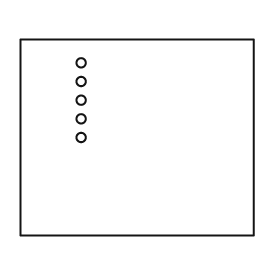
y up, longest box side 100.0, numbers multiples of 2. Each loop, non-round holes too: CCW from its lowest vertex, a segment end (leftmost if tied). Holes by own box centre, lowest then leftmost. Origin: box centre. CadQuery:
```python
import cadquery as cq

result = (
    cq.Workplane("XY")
    .moveTo(-50.0, -42.0)
    .lineTo(50.0, -42.0)
    .lineTo(50.0, 42.0)
    .lineTo(-50.0, 42.0)
    .close()
    .moveTo(-24.0, 0.0)
    .circle(2.0)
    .moveTo(-24.0, 8.0)
    .circle(2.0)
    .moveTo(-24.0, 16.0)
    .circle(2.0)
    .moveTo(-24.0, 24.0)
    .circle(2.0)
    .moveTo(-24.0, 32.0)
    .circle(2.0)
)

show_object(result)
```